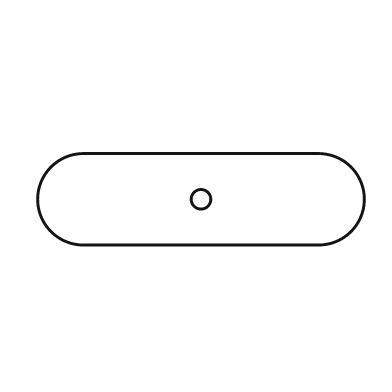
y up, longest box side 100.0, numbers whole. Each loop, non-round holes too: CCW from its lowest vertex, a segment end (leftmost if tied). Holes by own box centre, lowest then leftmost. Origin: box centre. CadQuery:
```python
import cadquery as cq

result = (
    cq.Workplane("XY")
    .moveTo(-36.0, -14.0)
    .lineTo(36.0, -14.0)
    .threePointArc((50.0, 0.0), (36.0, 14.0))
    .lineTo(-36.0, 14.0)
    .threePointArc((-50.0, 0.0), (-36.0, -14.0))
    .close()
    .moveTo(0.0, 0.0)
    .circle(3.0)
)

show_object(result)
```